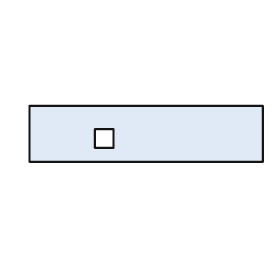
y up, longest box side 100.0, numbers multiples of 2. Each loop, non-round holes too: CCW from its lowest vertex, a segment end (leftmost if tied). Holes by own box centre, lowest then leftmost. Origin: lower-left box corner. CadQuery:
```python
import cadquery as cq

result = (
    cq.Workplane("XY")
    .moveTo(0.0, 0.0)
    .lineTo(100.0, 0.0)
    .lineTo(100.0, 24.0)
    .lineTo(0.0, 24.0)
    .close()
    .moveTo(28.0, 6.0)
    .lineTo(36.0, 6.0)
    .lineTo(36.0, 14.0)
    .lineTo(28.0, 14.0)
    .close()
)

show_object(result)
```